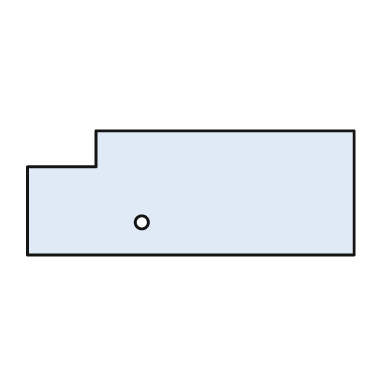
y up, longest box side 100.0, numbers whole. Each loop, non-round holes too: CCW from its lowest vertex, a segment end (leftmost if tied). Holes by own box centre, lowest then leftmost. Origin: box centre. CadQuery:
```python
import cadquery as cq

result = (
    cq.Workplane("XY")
    .moveTo(-50.0, -19.0)
    .lineTo(50.0, -19.0)
    .lineTo(50.0, 19.0)
    .lineTo(-29.0, 19.0)
    .lineTo(-29.0, 8.0)
    .lineTo(-50.0, 8.0)
    .close()
    .moveTo(-15.0, -9.0)
    .circle(2.0)
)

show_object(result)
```